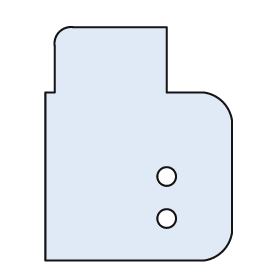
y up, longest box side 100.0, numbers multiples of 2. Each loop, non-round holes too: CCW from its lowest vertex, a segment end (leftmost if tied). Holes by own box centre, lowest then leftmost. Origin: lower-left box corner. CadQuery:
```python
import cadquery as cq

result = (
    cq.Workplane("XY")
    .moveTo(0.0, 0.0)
    .lineTo(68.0, 0.0)
    .threePointArc((76.0, 4.0), (80.0, 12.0))
    .lineTo(80.0, 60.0)
    .threePointArc((76.0, 68.0), (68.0, 72.0))
    .lineTo(52.0, 72.0)
    .lineTo(52.0, 100.0)
    .lineTo(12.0, 100.0)
    .threePointArc((6.0, 98.0), (4.0, 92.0))
    .lineTo(4.0, 72.0)
    .lineTo(0.0, 72.0)
    .close()
    .moveTo(52.0, 18.0)
    .circle(4.0)
    .moveTo(52.0, 36.0)
    .circle(4.0)
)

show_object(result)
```